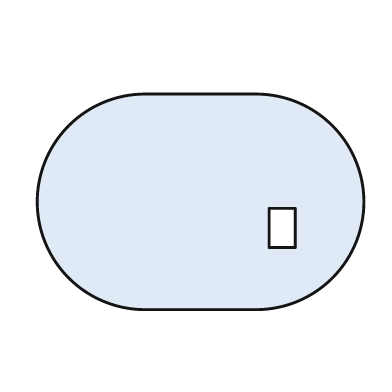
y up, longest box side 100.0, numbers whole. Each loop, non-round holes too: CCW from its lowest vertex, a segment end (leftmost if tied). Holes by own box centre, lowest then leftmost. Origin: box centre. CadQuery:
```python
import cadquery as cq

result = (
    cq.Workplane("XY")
    .moveTo(-17.0, -33.0)
    .lineTo(17.0, -33.0)
    .threePointArc((50.0, 0.0), (17.0, 33.0))
    .lineTo(-17.0, 33.0)
    .threePointArc((-50.0, 0.0), (-17.0, -33.0))
    .close()
    .moveTo(21.0, -14.0)
    .lineTo(29.0, -14.0)
    .lineTo(29.0, -2.0)
    .lineTo(21.0, -2.0)
    .close()
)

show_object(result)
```